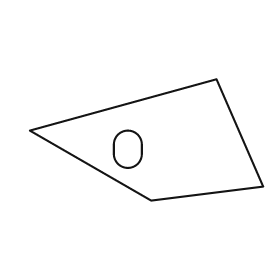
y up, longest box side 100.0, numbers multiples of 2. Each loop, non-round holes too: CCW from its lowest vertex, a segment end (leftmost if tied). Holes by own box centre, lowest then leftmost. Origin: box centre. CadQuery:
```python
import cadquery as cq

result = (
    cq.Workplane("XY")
    .moveTo(2.0, -26.0)
    .lineTo(50.0, -20.0)
    .lineTo(30.0, 26.0)
    .lineTo(-50.0, 4.0)
    .close()
    .moveTo(-14.0, -6.0)
    .threePointArc((-8.0, -12.0), (-2.0, -6.0))
    .lineTo(-2.0, -2.0)
    .threePointArc((-8.0, 4.0), (-14.0, -2.0))
    .close()
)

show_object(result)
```